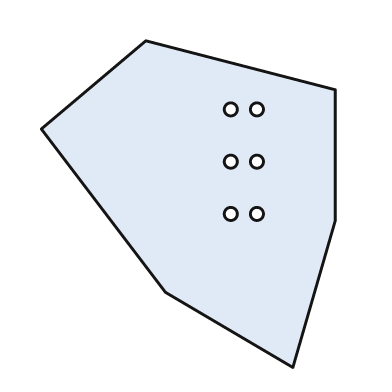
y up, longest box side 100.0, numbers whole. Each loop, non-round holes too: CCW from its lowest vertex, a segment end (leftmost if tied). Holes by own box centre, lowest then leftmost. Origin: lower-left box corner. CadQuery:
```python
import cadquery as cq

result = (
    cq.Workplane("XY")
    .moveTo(77.0, 0.0)
    .lineTo(90.0, 45.0)
    .lineTo(90.0, 85.0)
    .lineTo(32.0, 100.0)
    .lineTo(0.0, 73.0)
    .lineTo(38.0, 23.0)
    .close()
    .moveTo(58.0, 47.0)
    .circle(2.0)
    .moveTo(66.0, 47.0)
    .circle(2.0)
    .moveTo(58.0, 63.0)
    .circle(2.0)
    .moveTo(66.0, 63.0)
    .circle(2.0)
    .moveTo(58.0, 79.0)
    .circle(2.0)
    .moveTo(66.0, 79.0)
    .circle(2.0)
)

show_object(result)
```